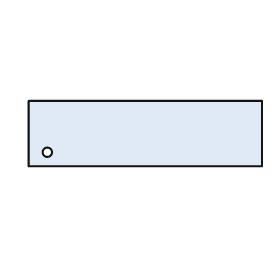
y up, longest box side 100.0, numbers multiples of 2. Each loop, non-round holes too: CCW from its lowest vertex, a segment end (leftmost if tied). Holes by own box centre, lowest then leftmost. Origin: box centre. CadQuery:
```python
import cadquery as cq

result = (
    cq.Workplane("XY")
    .moveTo(-50.0, -14.0)
    .lineTo(50.0, -14.0)
    .lineTo(50.0, 14.0)
    .lineTo(-50.0, 14.0)
    .close()
    .moveTo(-42.0, -8.0)
    .circle(2.0)
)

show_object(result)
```